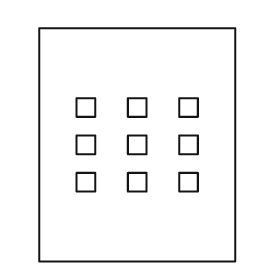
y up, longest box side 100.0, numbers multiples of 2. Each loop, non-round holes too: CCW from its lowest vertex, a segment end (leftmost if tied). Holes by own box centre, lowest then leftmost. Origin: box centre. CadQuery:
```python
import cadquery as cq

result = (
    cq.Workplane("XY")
    .moveTo(-42.0, -50.0)
    .lineTo(42.0, -50.0)
    .lineTo(42.0, 50.0)
    .lineTo(-42.0, 50.0)
    .close()
    .moveTo(-26.0, -20.0)
    .lineTo(-18.0, -20.0)
    .lineTo(-18.0, -12.0)
    .lineTo(-26.0, -12.0)
    .close()
    .moveTo(-4.0, -20.0)
    .lineTo(4.0, -20.0)
    .lineTo(4.0, -12.0)
    .lineTo(-4.0, -12.0)
    .close()
    .moveTo(18.0, -20.0)
    .lineTo(26.0, -20.0)
    .lineTo(26.0, -12.0)
    .lineTo(18.0, -12.0)
    .close()
    .moveTo(-26.0, -4.0)
    .lineTo(-18.0, -4.0)
    .lineTo(-18.0, 4.0)
    .lineTo(-26.0, 4.0)
    .close()
    .moveTo(-4.0, -4.0)
    .lineTo(4.0, -4.0)
    .lineTo(4.0, 4.0)
    .lineTo(-4.0, 4.0)
    .close()
    .moveTo(18.0, -4.0)
    .lineTo(26.0, -4.0)
    .lineTo(26.0, 4.0)
    .lineTo(18.0, 4.0)
    .close()
    .moveTo(-26.0, 12.0)
    .lineTo(-18.0, 12.0)
    .lineTo(-18.0, 20.0)
    .lineTo(-26.0, 20.0)
    .close()
    .moveTo(-4.0, 12.0)
    .lineTo(4.0, 12.0)
    .lineTo(4.0, 20.0)
    .lineTo(-4.0, 20.0)
    .close()
    .moveTo(18.0, 12.0)
    .lineTo(26.0, 12.0)
    .lineTo(26.0, 20.0)
    .lineTo(18.0, 20.0)
    .close()
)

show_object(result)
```